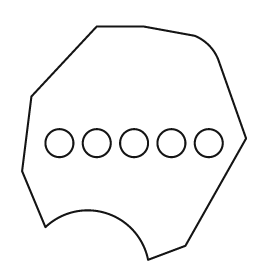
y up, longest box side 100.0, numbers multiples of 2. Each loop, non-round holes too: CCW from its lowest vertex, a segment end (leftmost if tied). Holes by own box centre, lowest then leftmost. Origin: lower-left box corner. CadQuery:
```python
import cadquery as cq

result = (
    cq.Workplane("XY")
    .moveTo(54.0, 0.0)
    .lineTo(70.0, 6.0)
    .lineTo(96.0, 52.0)
    .lineTo(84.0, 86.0)
    .threePointArc((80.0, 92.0), (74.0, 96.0))
    .lineTo(52.0, 100.0)
    .lineTo(32.0, 100.0)
    .lineTo(4.0, 70.0)
    .lineTo(0.0, 38.0)
    .lineTo(10.0, 14.0)
    .threePointArc((36.0, 20.0), (54.0, 0.0))
    .close()
    .moveTo(16.0, 50.0)
    .circle(6.0)
    .moveTo(32.0, 50.0)
    .circle(6.0)
    .moveTo(48.0, 50.0)
    .circle(6.0)
    .moveTo(64.0, 50.0)
    .circle(6.0)
    .moveTo(80.0, 50.0)
    .circle(6.0)
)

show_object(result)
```